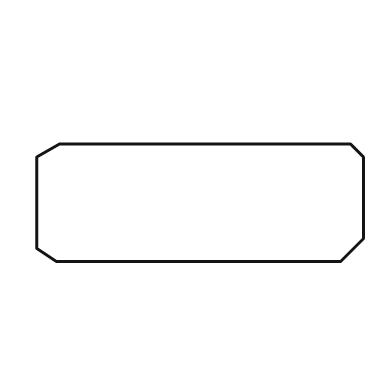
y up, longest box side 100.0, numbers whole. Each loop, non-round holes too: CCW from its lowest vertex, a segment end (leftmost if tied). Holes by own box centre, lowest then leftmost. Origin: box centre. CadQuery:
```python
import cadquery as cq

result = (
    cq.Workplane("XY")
    .moveTo(-44.0, -18.0)
    .lineTo(43.0, -18.0)
    .lineTo(50.0, -11.0)
    .lineTo(50.0, 14.0)
    .lineTo(46.0, 18.0)
    .lineTo(-43.0, 18.0)
    .lineTo(-50.0, 14.0)
    .lineTo(-50.0, -14.0)
    .close()
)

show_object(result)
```